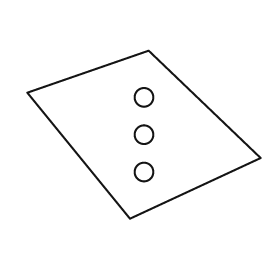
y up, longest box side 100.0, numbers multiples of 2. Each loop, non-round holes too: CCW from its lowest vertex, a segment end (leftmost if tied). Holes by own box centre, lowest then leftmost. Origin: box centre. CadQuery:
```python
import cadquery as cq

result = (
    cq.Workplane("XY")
    .moveTo(-6.0, -36.0)
    .lineTo(50.0, -10.0)
    .lineTo(2.0, 36.0)
    .lineTo(-50.0, 18.0)
    .close()
    .moveTo(0.0, -16.0)
    .circle(4.0)
    .moveTo(0.0, 0.0)
    .circle(4.0)
    .moveTo(0.0, 16.0)
    .circle(4.0)
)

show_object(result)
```